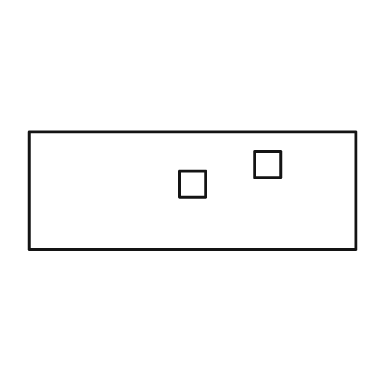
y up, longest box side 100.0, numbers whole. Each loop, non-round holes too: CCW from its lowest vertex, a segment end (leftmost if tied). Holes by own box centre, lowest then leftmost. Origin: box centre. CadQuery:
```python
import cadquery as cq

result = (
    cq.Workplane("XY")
    .moveTo(-50.0, -18.0)
    .lineTo(50.0, -18.0)
    .lineTo(50.0, 18.0)
    .lineTo(-50.0, 18.0)
    .close()
    .moveTo(-4.0, -2.0)
    .lineTo(4.0, -2.0)
    .lineTo(4.0, 6.0)
    .lineTo(-4.0, 6.0)
    .close()
    .moveTo(19.0, 4.0)
    .lineTo(27.0, 4.0)
    .lineTo(27.0, 12.0)
    .lineTo(19.0, 12.0)
    .close()
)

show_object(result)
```